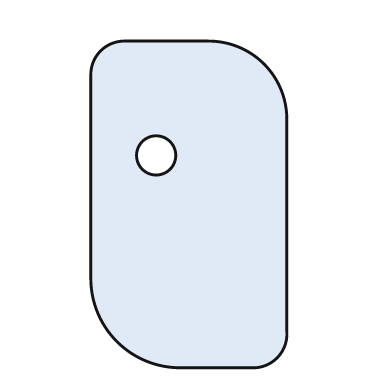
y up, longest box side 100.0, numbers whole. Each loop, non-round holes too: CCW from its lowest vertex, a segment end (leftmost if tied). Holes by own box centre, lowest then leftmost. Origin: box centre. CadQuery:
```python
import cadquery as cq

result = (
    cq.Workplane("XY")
    .moveTo(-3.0, -50.0)
    .lineTo(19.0, -50.0)
    .threePointArc((27.0, -47.0), (30.0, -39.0))
    .lineTo(30.0, 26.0)
    .threePointArc((23.0, 43.0), (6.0, 50.0))
    .lineTo(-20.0, 50.0)
    .threePointArc((-27.0, 47.0), (-30.0, 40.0))
    .lineTo(-30.0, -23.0)
    .threePointArc((-22.0, -42.0), (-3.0, -50.0))
    .close()
    .moveTo(-10.0, 15.0)
    .circle(6.0)
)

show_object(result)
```